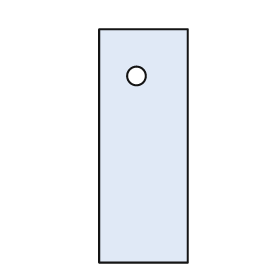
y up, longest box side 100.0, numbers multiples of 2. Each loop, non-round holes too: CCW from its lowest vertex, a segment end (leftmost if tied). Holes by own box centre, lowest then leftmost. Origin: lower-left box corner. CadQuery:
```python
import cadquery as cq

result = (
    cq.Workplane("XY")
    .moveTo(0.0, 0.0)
    .lineTo(38.0, 0.0)
    .lineTo(38.0, 100.0)
    .lineTo(0.0, 100.0)
    .close()
    .moveTo(16.0, 80.0)
    .circle(4.0)
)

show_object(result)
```